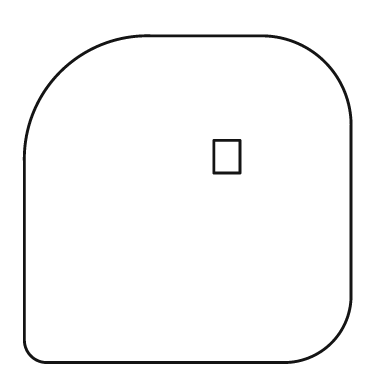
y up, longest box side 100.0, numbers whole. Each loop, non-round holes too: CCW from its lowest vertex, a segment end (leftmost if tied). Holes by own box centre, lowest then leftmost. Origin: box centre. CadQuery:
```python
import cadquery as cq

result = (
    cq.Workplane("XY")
    .moveTo(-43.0, -50.0)
    .lineTo(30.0, -50.0)
    .threePointArc((44.0, -44.0), (50.0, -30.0))
    .lineTo(50.0, 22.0)
    .threePointArc((42.0, 42.0), (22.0, 50.0))
    .lineTo(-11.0, 50.0)
    .threePointArc((-39.0, 39.0), (-50.0, 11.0))
    .lineTo(-50.0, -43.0)
    .threePointArc((-48.0, -48.0), (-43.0, -50.0))
    .close()
    .moveTo(8.0, 8.0)
    .lineTo(16.0, 8.0)
    .lineTo(16.0, 18.0)
    .lineTo(8.0, 18.0)
    .close()
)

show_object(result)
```